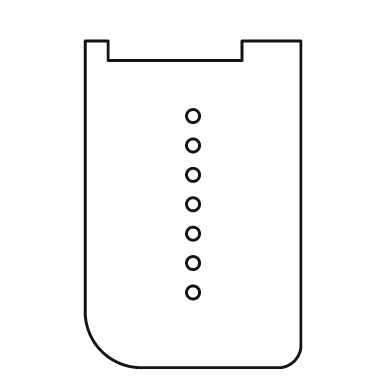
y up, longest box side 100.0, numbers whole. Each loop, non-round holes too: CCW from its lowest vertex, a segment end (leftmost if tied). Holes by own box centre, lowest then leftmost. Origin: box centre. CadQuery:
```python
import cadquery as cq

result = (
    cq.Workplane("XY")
    .moveTo(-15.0, -50.0)
    .lineTo(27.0, -50.0)
    .threePointArc((31.0, -48.0), (33.0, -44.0))
    .lineTo(33.0, 50.0)
    .lineTo(15.0, 50.0)
    .lineTo(15.0, 44.0)
    .lineTo(-26.0, 44.0)
    .lineTo(-26.0, 50.0)
    .lineTo(-33.0, 50.0)
    .lineTo(-33.0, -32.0)
    .threePointArc((-28.0, -45.0), (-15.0, -50.0))
    .close()
    .moveTo(0.0, -27.0)
    .circle(2.0)
    .moveTo(0.0, -18.0)
    .circle(2.0)
    .moveTo(0.0, -9.0)
    .circle(2.0)
    .moveTo(0.0, 0.0)
    .circle(2.0)
    .moveTo(0.0, 9.0)
    .circle(2.0)
    .moveTo(0.0, 18.0)
    .circle(2.0)
    .moveTo(0.0, 27.0)
    .circle(2.0)
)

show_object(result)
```